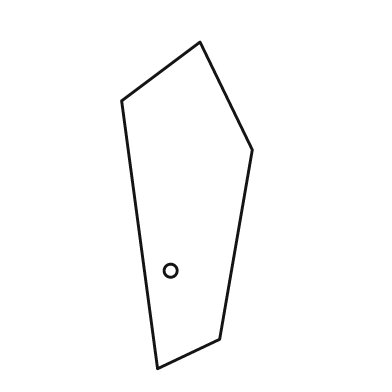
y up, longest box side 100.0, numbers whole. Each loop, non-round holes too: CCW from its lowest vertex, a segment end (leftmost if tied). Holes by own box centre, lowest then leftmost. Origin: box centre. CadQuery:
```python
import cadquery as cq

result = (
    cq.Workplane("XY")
    .moveTo(-9.0, -50.0)
    .lineTo(10.0, -41.0)
    .lineTo(20.0, 17.0)
    .lineTo(4.0, 50.0)
    .lineTo(-20.0, 32.0)
    .close()
    .moveTo(-5.0, -20.0)
    .circle(2.0)
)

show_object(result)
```